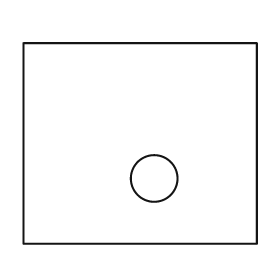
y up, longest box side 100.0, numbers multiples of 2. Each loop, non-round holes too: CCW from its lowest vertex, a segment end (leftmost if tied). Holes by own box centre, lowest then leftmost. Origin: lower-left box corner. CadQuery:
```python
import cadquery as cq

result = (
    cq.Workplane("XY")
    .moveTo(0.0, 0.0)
    .lineTo(100.0, 0.0)
    .lineTo(100.0, 86.0)
    .lineTo(0.0, 86.0)
    .close()
    .moveTo(56.0, 28.0)
    .circle(10.0)
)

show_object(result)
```